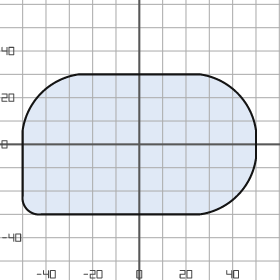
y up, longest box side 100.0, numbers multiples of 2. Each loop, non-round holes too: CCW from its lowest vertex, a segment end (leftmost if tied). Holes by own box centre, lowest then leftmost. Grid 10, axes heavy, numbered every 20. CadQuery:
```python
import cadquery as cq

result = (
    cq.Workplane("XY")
    .moveTo(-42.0, -30.0)
    .lineTo(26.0, -30.0)
    .threePointArc((42.0, -22.0), (50.0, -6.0))
    .lineTo(50.0, 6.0)
    .threePointArc((42.0, 22.0), (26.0, 30.0))
    .lineTo(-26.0, 30.0)
    .threePointArc((-42.0, 22.0), (-50.0, 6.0))
    .lineTo(-50.0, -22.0)
    .threePointArc((-48.0, -28.0), (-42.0, -30.0))
    .close()
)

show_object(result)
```